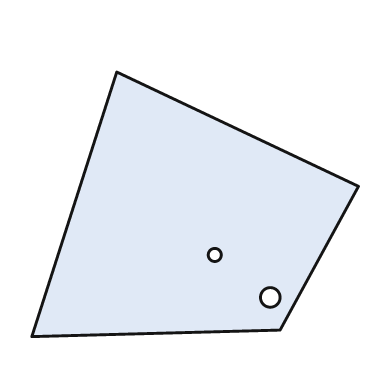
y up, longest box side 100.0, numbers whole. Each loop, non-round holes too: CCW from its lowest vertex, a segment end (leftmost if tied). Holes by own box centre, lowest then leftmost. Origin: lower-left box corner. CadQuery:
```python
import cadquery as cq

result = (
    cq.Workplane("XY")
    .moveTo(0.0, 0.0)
    .lineTo(76.0, 2.0)
    .lineTo(100.0, 46.0)
    .lineTo(26.0, 81.0)
    .close()
    .moveTo(73.0, 12.0)
    .circle(3.0)
    .moveTo(56.0, 25.0)
    .circle(2.0)
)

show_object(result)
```